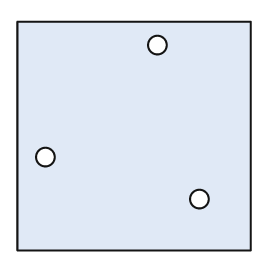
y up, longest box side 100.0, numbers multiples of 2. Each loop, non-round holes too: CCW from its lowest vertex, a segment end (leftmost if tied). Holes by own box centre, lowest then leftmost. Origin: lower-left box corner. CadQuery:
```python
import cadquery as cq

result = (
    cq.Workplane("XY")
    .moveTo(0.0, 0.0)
    .lineTo(100.0, 0.0)
    .lineTo(100.0, 98.0)
    .lineTo(0.0, 98.0)
    .close()
    .moveTo(78.0, 22.0)
    .circle(4.0)
    .moveTo(12.0, 40.0)
    .circle(4.0)
    .moveTo(60.0, 88.0)
    .circle(4.0)
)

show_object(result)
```